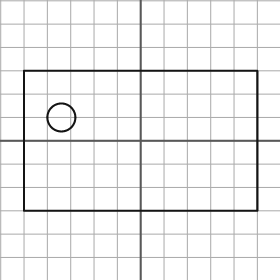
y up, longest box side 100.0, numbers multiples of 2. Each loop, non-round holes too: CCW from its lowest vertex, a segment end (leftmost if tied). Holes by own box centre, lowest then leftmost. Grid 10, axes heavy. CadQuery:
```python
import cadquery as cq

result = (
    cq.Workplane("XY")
    .moveTo(-50.0, -30.0)
    .lineTo(50.0, -30.0)
    .lineTo(50.0, 30.0)
    .lineTo(-50.0, 30.0)
    .close()
    .moveTo(-34.0, 10.0)
    .circle(6.0)
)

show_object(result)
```